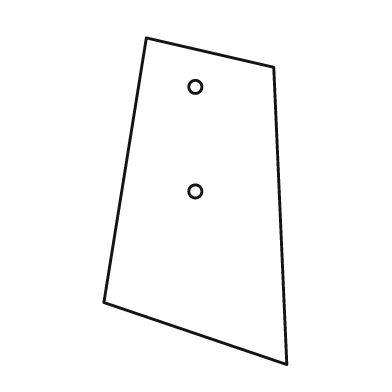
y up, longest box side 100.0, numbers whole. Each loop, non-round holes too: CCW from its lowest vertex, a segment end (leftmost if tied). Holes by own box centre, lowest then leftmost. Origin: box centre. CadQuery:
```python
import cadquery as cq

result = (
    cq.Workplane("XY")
    .moveTo(28.0, -50.0)
    .lineTo(24.0, 41.0)
    .lineTo(-15.0, 50.0)
    .lineTo(-28.0, -31.0)
    .close()
    .moveTo(0.0, 3.0)
    .circle(2.0)
    .moveTo(0.0, 35.0)
    .circle(2.0)
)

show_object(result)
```